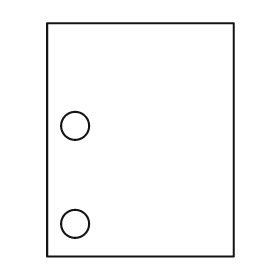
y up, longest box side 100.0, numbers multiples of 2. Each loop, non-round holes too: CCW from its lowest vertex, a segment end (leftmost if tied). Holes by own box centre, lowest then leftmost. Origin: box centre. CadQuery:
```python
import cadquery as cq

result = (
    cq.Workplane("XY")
    .moveTo(-40.0, -50.0)
    .lineTo(40.0, -50.0)
    .lineTo(40.0, 50.0)
    .lineTo(-40.0, 50.0)
    .close()
    .moveTo(-28.0, -36.0)
    .circle(6.0)
    .moveTo(-28.0, 6.0)
    .circle(6.0)
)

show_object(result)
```